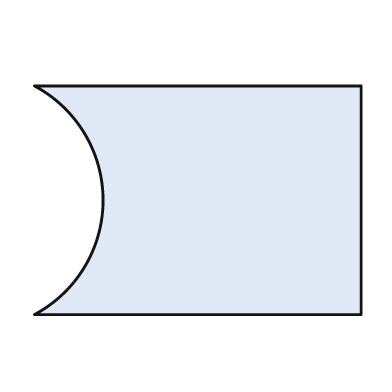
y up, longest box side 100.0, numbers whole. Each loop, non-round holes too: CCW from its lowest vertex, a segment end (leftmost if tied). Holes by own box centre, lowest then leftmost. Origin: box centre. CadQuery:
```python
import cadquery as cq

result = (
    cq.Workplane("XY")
    .moveTo(-50.0, -35.0)
    .lineTo(50.0, -35.0)
    .lineTo(50.0, 35.0)
    .lineTo(-50.0, 35.0)
    .threePointArc((-29.0, 0.0), (-50.0, -35.0))
    .close()
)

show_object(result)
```